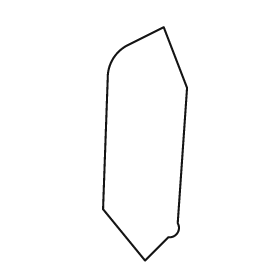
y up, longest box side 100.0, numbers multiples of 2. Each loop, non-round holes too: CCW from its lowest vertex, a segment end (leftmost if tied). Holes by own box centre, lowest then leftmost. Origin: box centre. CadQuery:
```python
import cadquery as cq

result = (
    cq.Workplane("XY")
    .moveTo(0.0, -50.0)
    .lineTo(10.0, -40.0)
    .threePointArc((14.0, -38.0), (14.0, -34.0))
    .lineTo(18.0, 24.0)
    .lineTo(8.0, 50.0)
    .lineTo(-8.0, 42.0)
    .threePointArc((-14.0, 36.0), (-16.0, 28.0))
    .lineTo(-18.0, -28.0)
    .close()
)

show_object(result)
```